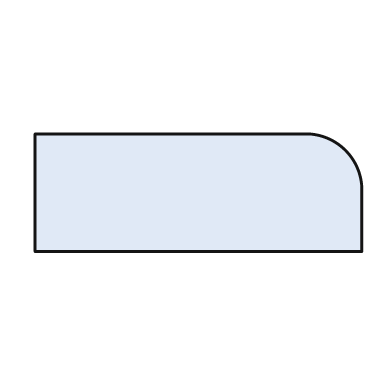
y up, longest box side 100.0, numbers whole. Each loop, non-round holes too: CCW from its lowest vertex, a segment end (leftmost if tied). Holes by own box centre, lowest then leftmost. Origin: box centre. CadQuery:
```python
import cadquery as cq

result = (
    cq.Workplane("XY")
    .moveTo(-50.0, -18.0)
    .lineTo(50.0, -18.0)
    .lineTo(50.0, 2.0)
    .threePointArc((45.0, 13.0), (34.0, 18.0))
    .lineTo(-50.0, 18.0)
    .close()
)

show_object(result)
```